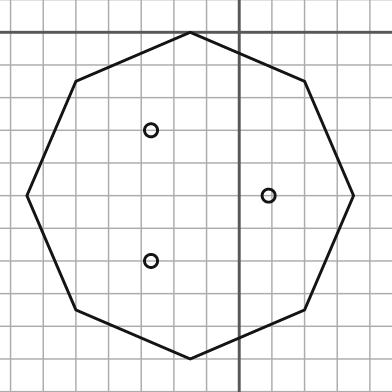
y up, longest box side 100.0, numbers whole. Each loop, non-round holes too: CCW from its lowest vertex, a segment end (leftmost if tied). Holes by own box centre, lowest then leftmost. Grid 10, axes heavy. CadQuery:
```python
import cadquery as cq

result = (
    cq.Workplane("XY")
    .moveTo(-15.0, -100.0)
    .lineTo(20.0, -85.0)
    .lineTo(35.0, -50.0)
    .lineTo(20.0, -15.0)
    .lineTo(-15.0, 0.0)
    .lineTo(-50.0, -15.0)
    .lineTo(-65.0, -50.0)
    .lineTo(-50.0, -85.0)
    .close()
    .moveTo(-27.0, -70.0)
    .circle(2.0)
    .moveTo(9.0, -50.0)
    .circle(2.0)
    .moveTo(-27.0, -30.0)
    .circle(2.0)
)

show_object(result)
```